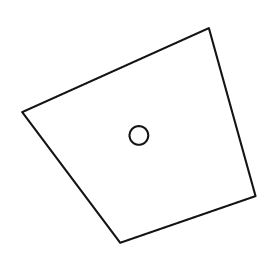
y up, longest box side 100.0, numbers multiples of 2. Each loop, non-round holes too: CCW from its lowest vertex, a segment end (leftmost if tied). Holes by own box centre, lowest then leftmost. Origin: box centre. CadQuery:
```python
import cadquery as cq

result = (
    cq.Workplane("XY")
    .moveTo(-8.0, -46.0)
    .lineTo(50.0, -26.0)
    .lineTo(30.0, 46.0)
    .lineTo(-50.0, 10.0)
    .close()
    .moveTo(0.0, 0.0)
    .circle(4.0)
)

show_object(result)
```